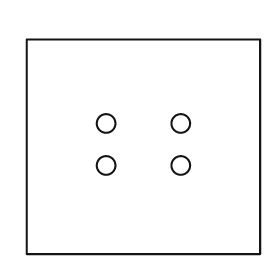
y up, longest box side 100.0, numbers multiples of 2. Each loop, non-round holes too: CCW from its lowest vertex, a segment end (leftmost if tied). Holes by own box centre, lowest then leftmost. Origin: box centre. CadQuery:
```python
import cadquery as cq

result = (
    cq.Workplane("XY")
    .moveTo(-50.0, -46.0)
    .lineTo(50.0, -46.0)
    .lineTo(50.0, 46.0)
    .lineTo(-50.0, 46.0)
    .close()
    .moveTo(-16.0, -8.0)
    .circle(4.0)
    .moveTo(16.0, -8.0)
    .circle(4.0)
    .moveTo(-16.0, 10.0)
    .circle(4.0)
    .moveTo(16.0, 10.0)
    .circle(4.0)
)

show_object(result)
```